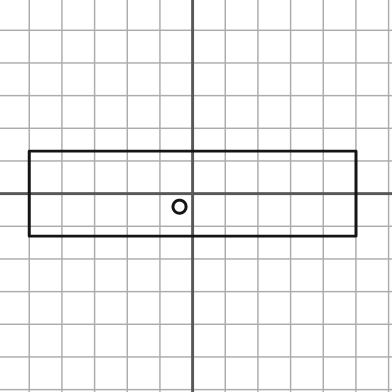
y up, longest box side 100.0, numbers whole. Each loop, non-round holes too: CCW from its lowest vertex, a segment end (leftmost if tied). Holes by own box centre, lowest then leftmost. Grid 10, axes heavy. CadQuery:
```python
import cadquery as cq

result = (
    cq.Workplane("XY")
    .moveTo(-50.0, -13.0)
    .lineTo(50.0, -13.0)
    .lineTo(50.0, 13.0)
    .lineTo(-50.0, 13.0)
    .close()
    .moveTo(-4.0, -4.0)
    .circle(2.0)
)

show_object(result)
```